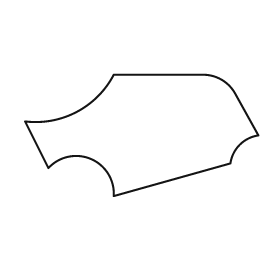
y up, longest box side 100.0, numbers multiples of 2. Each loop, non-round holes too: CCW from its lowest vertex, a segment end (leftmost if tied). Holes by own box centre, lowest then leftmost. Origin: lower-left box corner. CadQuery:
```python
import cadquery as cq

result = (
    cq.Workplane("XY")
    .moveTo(38.0, 0.0)
    .lineTo(88.0, 14.0)
    .threePointArc((92.0, 22.0), (100.0, 26.0))
    .lineTo(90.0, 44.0)
    .threePointArc((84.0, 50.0), (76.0, 52.0))
    .lineTo(38.0, 52.0)
    .threePointArc((22.0, 36.0), (0.0, 32.0))
    .lineTo(10.0, 12.0)
    .threePointArc((28.0, 16.0), (38.0, 0.0))
    .close()
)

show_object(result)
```